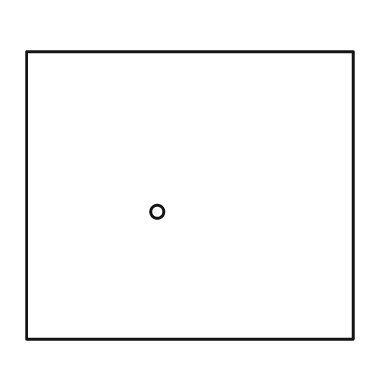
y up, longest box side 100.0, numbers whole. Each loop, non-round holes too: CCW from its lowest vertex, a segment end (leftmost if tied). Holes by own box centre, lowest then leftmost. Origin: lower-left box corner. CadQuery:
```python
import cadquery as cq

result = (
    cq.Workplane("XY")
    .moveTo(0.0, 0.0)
    .lineTo(100.0, 0.0)
    .lineTo(100.0, 88.0)
    .lineTo(0.0, 88.0)
    .close()
    .moveTo(40.0, 39.0)
    .circle(2.0)
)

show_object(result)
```